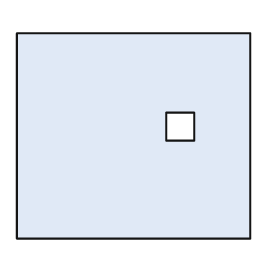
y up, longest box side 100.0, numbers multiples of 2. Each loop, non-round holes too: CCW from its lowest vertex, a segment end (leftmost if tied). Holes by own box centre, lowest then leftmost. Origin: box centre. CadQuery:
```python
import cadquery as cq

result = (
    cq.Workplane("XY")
    .moveTo(-50.0, -44.0)
    .lineTo(50.0, -44.0)
    .lineTo(50.0, 44.0)
    .lineTo(-50.0, 44.0)
    .close()
    .moveTo(14.0, -2.0)
    .lineTo(26.0, -2.0)
    .lineTo(26.0, 10.0)
    .lineTo(14.0, 10.0)
    .close()
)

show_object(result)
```